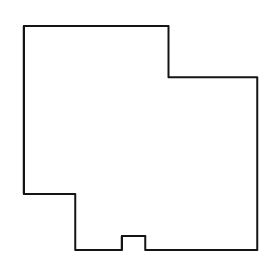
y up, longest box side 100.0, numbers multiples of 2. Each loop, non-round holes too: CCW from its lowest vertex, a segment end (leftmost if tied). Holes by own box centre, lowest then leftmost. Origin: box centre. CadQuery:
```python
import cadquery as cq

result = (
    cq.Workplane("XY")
    .moveTo(-28.0, -48.0)
    .lineTo(-8.0, -48.0)
    .lineTo(-8.0, -42.0)
    .lineTo(2.0, -42.0)
    .lineTo(2.0, -48.0)
    .lineTo(50.0, -48.0)
    .lineTo(50.0, 26.0)
    .lineTo(12.0, 26.0)
    .lineTo(12.0, 48.0)
    .lineTo(-50.0, 48.0)
    .lineTo(-50.0, -24.0)
    .lineTo(-28.0, -24.0)
    .close()
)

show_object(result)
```